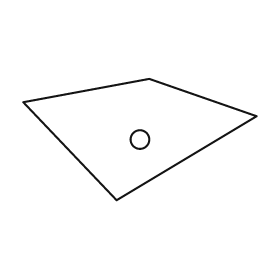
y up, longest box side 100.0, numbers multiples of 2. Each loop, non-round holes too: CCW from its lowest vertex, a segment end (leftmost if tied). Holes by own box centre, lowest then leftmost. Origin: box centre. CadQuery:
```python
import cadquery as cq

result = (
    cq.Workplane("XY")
    .moveTo(-10.0, -26.0)
    .lineTo(50.0, 10.0)
    .lineTo(4.0, 26.0)
    .lineTo(-50.0, 16.0)
    .close()
    .moveTo(0.0, 0.0)
    .circle(4.0)
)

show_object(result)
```